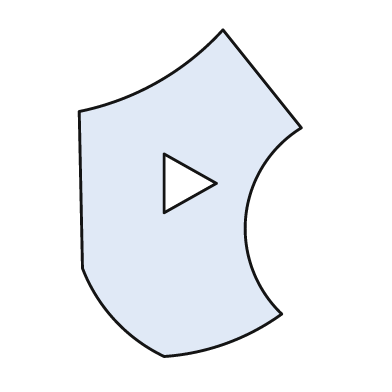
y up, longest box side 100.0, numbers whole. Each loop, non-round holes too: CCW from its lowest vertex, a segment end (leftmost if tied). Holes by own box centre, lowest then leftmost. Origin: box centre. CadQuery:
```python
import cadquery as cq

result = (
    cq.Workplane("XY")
    .moveTo(-8.0, -50.0)
    .threePointArc((11.0, -46.0), (28.0, -37.0))
    .threePointArc((17.0, -7.0), (34.0, 20.0))
    .lineTo(10.0, 50.0)
    .threePointArc((-10.0, 34.0), (-34.0, 25.0))
    .lineTo(-33.0, -23.0)
    .threePointArc((-23.0, -39.0), (-8.0, -50.0))
    .close()
    .moveTo(-8.0, -6.0)
    .lineTo(8.0, 3.0)
    .lineTo(-8.0, 12.0)
    .close()
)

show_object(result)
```